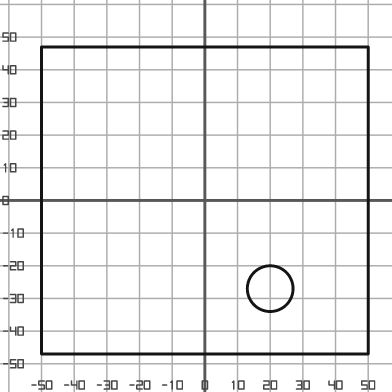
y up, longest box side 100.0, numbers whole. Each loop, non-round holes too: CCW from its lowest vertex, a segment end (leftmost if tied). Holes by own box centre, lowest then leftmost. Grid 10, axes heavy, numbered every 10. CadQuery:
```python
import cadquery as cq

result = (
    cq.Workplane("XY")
    .moveTo(-50.0, -47.0)
    .lineTo(50.0, -47.0)
    .lineTo(50.0, 47.0)
    .lineTo(-50.0, 47.0)
    .close()
    .moveTo(20.0, -27.0)
    .circle(7.0)
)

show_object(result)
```